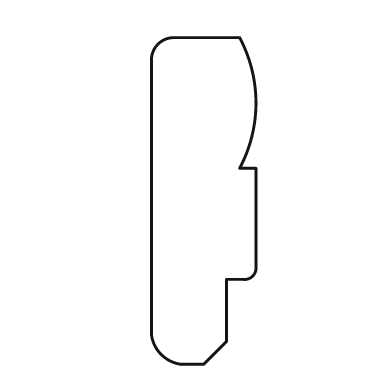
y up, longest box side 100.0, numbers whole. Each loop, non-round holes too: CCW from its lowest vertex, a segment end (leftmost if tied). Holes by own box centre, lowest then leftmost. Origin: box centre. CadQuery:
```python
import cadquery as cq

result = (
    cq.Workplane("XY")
    .moveTo(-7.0, -50.0)
    .lineTo(0.0, -50.0)
    .lineTo(7.0, -43.0)
    .lineTo(7.0, -24.0)
    .lineTo(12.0, -24.0)
    .threePointArc((15.0, -23.0), (16.0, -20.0))
    .lineTo(16.0, 10.0)
    .lineTo(11.0, 10.0)
    .threePointArc((16.0, 30.0), (11.0, 50.0))
    .lineTo(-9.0, 50.0)
    .threePointArc((-14.0, 48.0), (-16.0, 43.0))
    .lineTo(-16.0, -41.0)
    .threePointArc((-13.0, -47.0), (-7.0, -50.0))
    .close()
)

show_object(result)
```